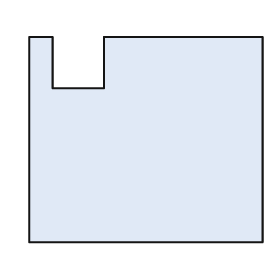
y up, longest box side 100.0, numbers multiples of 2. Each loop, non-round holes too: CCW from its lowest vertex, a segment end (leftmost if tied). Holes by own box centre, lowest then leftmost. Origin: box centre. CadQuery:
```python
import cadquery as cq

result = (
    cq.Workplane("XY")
    .moveTo(-50.0, -44.0)
    .lineTo(50.0, -44.0)
    .lineTo(50.0, 44.0)
    .lineTo(-18.0, 44.0)
    .lineTo(-18.0, 22.0)
    .lineTo(-40.0, 22.0)
    .lineTo(-40.0, 44.0)
    .lineTo(-50.0, 44.0)
    .close()
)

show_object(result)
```